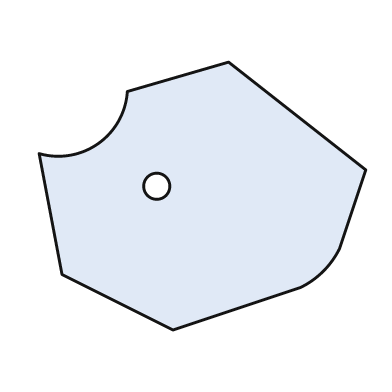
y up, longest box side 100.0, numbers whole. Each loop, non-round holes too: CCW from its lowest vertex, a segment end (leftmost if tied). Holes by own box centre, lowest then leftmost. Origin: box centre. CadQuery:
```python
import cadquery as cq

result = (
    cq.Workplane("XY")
    .moveTo(-9.0, -41.0)
    .lineTo(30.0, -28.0)
    .threePointArc((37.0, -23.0), (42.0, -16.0))
    .lineTo(50.0, 8.0)
    .lineTo(8.0, 41.0)
    .lineTo(-23.0, 32.0)
    .threePointArc((-32.0, 16.0), (-50.0, 13.0))
    .lineTo(-43.0, -24.0)
    .close()
    .moveTo(-14.0, 3.0)
    .circle(4.0)
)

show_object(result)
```